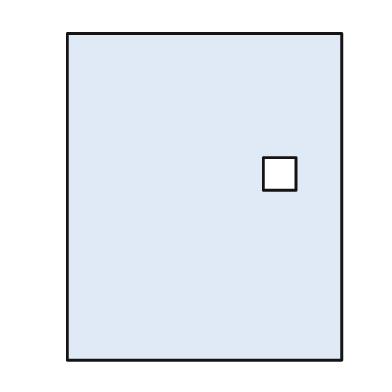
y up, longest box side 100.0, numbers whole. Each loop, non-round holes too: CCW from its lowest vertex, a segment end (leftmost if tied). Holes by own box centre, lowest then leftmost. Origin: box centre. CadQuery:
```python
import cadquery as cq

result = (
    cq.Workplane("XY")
    .moveTo(-42.0, -50.0)
    .lineTo(42.0, -50.0)
    .lineTo(42.0, 50.0)
    .lineTo(-42.0, 50.0)
    .close()
    .moveTo(18.0, 2.0)
    .lineTo(28.0, 2.0)
    .lineTo(28.0, 12.0)
    .lineTo(18.0, 12.0)
    .close()
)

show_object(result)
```